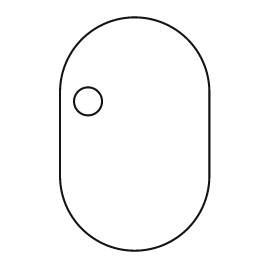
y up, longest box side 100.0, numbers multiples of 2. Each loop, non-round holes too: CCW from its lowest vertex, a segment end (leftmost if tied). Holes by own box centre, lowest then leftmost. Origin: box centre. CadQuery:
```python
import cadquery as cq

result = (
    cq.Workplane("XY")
    .moveTo(-32.0, -18.0)
    .threePointArc((0.0, -50.0), (32.0, -18.0))
    .lineTo(32.0, 18.0)
    .threePointArc((0.0, 50.0), (-32.0, 18.0))
    .close()
    .moveTo(-20.0, 14.0)
    .circle(6.0)
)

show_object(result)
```